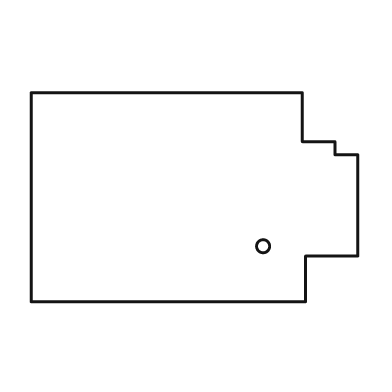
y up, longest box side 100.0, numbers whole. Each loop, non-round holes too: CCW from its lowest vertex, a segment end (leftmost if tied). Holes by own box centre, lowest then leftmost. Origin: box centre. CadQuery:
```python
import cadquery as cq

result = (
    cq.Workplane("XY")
    .moveTo(-50.0, -32.0)
    .lineTo(34.0, -32.0)
    .lineTo(34.0, -18.0)
    .lineTo(50.0, -18.0)
    .lineTo(50.0, 13.0)
    .lineTo(43.0, 13.0)
    .lineTo(43.0, 17.0)
    .lineTo(33.0, 17.0)
    .lineTo(33.0, 32.0)
    .lineTo(-50.0, 32.0)
    .close()
    .moveTo(21.0, -15.0)
    .circle(2.0)
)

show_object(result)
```